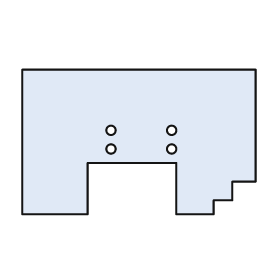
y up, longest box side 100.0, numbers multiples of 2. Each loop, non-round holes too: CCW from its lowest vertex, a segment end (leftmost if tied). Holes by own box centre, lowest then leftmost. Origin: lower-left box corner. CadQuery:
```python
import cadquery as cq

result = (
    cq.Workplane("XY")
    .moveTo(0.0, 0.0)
    .lineTo(28.0, 0.0)
    .lineTo(28.0, 22.0)
    .lineTo(66.0, 22.0)
    .lineTo(66.0, 0.0)
    .lineTo(82.0, 0.0)
    .lineTo(82.0, 6.0)
    .lineTo(90.0, 6.0)
    .lineTo(90.0, 14.0)
    .lineTo(100.0, 14.0)
    .lineTo(100.0, 62.0)
    .lineTo(0.0, 62.0)
    .close()
    .moveTo(38.0, 28.0)
    .circle(2.0)
    .moveTo(64.0, 28.0)
    .circle(2.0)
    .moveTo(38.0, 36.0)
    .circle(2.0)
    .moveTo(64.0, 36.0)
    .circle(2.0)
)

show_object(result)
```